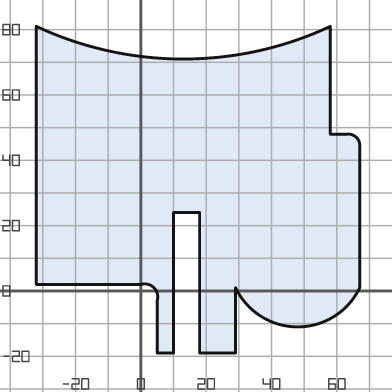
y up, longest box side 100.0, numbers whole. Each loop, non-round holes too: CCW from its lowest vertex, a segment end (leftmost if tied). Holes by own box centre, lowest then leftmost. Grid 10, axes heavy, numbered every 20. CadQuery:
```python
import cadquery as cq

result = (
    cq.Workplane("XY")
    .moveTo(5.0, -19.0)
    .lineTo(10.0, -19.0)
    .lineTo(10.0, 24.0)
    .lineTo(18.0, 24.0)
    .lineTo(18.0, -19.0)
    .lineTo(29.0, -19.0)
    .lineTo(29.0, 1.0)
    .threePointArc((48.0, -11.0), (67.0, 1.0))
    .lineTo(67.0, 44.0)
    .threePointArc((66.0, 47.0), (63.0, 48.0))
    .lineTo(58.0, 48.0)
    .lineTo(58.0, 81.0)
    .threePointArc((13.0, 71.0), (-32.0, 81.0))
    .lineTo(-32.0, 2.0)
    .lineTo(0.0, 2.0)
    .threePointArc((4.0, 1.0), (5.0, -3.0))
    .close()
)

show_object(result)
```